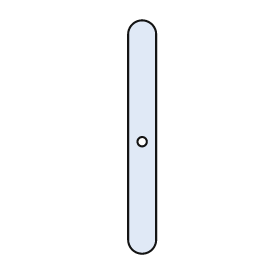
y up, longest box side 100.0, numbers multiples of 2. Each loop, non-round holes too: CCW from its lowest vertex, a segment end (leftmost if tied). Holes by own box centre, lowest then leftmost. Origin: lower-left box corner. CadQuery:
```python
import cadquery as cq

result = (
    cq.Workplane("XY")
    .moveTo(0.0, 6.0)
    .threePointArc((6.0, 0.0), (12.0, 6.0))
    .lineTo(12.0, 94.0)
    .threePointArc((6.0, 100.0), (0.0, 94.0))
    .close()
    .moveTo(6.0, 48.0)
    .circle(2.0)
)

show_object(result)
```